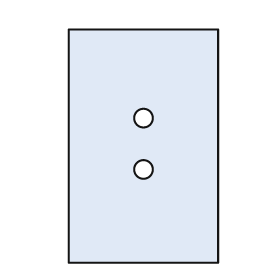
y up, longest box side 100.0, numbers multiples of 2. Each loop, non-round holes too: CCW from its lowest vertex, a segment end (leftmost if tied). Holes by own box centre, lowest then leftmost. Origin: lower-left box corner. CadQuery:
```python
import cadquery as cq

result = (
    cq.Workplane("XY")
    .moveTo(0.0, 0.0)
    .lineTo(64.0, 0.0)
    .lineTo(64.0, 100.0)
    .lineTo(0.0, 100.0)
    .close()
    .moveTo(32.0, 40.0)
    .circle(4.0)
    .moveTo(32.0, 62.0)
    .circle(4.0)
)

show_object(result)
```